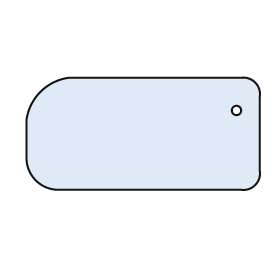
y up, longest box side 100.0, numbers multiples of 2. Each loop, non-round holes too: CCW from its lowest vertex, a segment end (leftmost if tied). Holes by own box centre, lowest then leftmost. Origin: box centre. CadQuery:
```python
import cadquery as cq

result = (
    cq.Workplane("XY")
    .moveTo(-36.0, -24.0)
    .lineTo(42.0, -24.0)
    .threePointArc((48.0, -22.0), (50.0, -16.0))
    .lineTo(50.0, 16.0)
    .threePointArc((48.0, 22.0), (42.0, 24.0))
    .lineTo(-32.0, 24.0)
    .threePointArc((-44.0, 18.0), (-50.0, 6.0))
    .lineTo(-50.0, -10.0)
    .threePointArc((-46.0, -20.0), (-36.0, -24.0))
    .close()
    .moveTo(40.0, 10.0)
    .circle(2.0)
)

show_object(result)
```